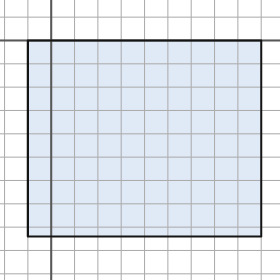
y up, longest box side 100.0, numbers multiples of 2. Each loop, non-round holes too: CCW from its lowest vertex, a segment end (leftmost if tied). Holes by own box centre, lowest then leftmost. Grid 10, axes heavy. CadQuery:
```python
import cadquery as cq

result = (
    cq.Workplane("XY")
    .moveTo(-10.0, -84.0)
    .lineTo(90.0, -84.0)
    .lineTo(90.0, 0.0)
    .lineTo(-10.0, 0.0)
    .close()
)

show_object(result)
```